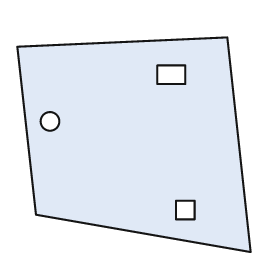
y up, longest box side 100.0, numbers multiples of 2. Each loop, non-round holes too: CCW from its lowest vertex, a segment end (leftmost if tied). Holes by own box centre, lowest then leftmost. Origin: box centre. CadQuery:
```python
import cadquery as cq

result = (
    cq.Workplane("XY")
    .moveTo(50.0, -46.0)
    .lineTo(40.0, 46.0)
    .lineTo(-50.0, 42.0)
    .lineTo(-42.0, -30.0)
    .close()
    .moveTo(18.0, -32.0)
    .lineTo(26.0, -32.0)
    .lineTo(26.0, -24.0)
    .lineTo(18.0, -24.0)
    .close()
    .moveTo(-36.0, 10.0)
    .circle(4.0)
    .moveTo(10.0, 26.0)
    .lineTo(22.0, 26.0)
    .lineTo(22.0, 34.0)
    .lineTo(10.0, 34.0)
    .close()
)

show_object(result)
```